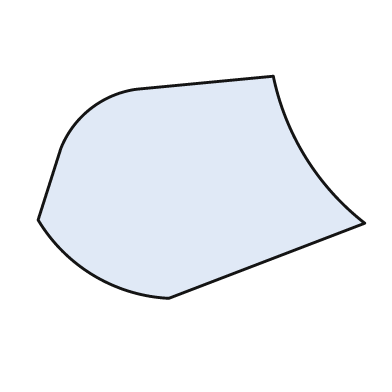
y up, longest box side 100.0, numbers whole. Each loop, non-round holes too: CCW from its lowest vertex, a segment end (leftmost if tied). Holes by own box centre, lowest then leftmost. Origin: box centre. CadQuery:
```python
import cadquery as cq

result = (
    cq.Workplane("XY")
    .moveTo(-10.0, -34.0)
    .lineTo(50.0, -11.0)
    .threePointArc((32.0, 9.0), (22.0, 34.0))
    .lineTo(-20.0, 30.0)
    .threePointArc((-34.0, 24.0), (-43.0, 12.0))
    .lineTo(-50.0, -10.0)
    .threePointArc((-33.0, -27.0), (-10.0, -34.0))
    .close()
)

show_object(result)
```